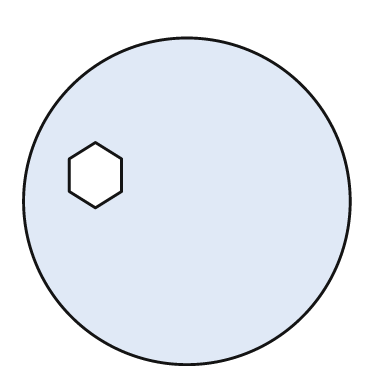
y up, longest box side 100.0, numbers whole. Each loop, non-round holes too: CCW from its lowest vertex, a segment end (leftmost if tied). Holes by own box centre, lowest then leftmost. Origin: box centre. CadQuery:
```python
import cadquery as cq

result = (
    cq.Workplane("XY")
    .moveTo(0.0, 0.0)
    .circle(50.0)
    .moveTo(-28.0, -2.0)
    .lineTo(-20.0, 3.0)
    .lineTo(-20.0, 13.0)
    .lineTo(-28.0, 18.0)
    .lineTo(-36.0, 13.0)
    .lineTo(-36.0, 3.0)
    .close()
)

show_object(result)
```